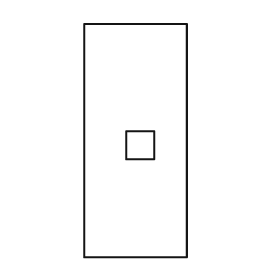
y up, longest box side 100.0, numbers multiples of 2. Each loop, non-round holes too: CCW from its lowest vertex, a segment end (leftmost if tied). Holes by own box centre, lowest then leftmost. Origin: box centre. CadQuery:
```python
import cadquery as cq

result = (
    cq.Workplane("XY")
    .moveTo(-22.0, -50.0)
    .lineTo(22.0, -50.0)
    .lineTo(22.0, 50.0)
    .lineTo(-22.0, 50.0)
    .close()
    .moveTo(-4.0, -8.0)
    .lineTo(8.0, -8.0)
    .lineTo(8.0, 4.0)
    .lineTo(-4.0, 4.0)
    .close()
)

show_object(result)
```